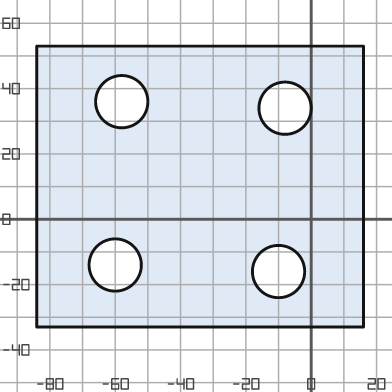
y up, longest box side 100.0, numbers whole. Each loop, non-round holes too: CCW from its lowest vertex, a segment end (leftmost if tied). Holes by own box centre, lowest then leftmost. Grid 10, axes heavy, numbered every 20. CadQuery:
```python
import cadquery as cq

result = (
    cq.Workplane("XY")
    .moveTo(-84.0, -33.0)
    .lineTo(16.0, -33.0)
    .lineTo(16.0, 53.0)
    .lineTo(-84.0, 53.0)
    .close()
    .moveTo(-10.0, -16.0)
    .circle(8.0)
    .moveTo(-60.0, -14.0)
    .circle(8.0)
    .moveTo(-8.0, 34.0)
    .circle(8.0)
    .moveTo(-58.0, 36.0)
    .circle(8.0)
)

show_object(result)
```